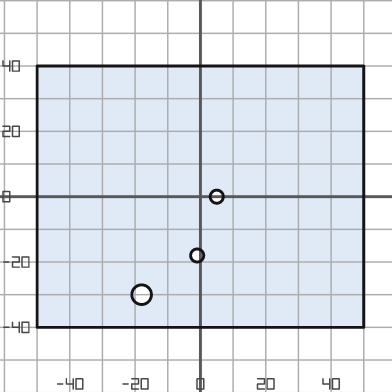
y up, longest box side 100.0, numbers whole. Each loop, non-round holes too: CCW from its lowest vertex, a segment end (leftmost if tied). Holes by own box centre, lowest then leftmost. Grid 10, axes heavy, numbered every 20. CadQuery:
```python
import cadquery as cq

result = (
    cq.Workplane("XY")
    .moveTo(-50.0, -40.0)
    .lineTo(50.0, -40.0)
    .lineTo(50.0, 40.0)
    .lineTo(-50.0, 40.0)
    .close()
    .moveTo(-18.0, -30.0)
    .circle(3.0)
    .moveTo(-1.0, -18.0)
    .circle(2.0)
    .moveTo(5.0, 0.0)
    .circle(2.0)
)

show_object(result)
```